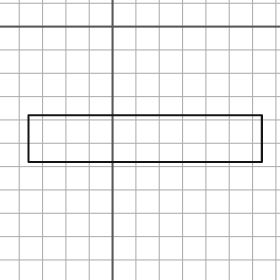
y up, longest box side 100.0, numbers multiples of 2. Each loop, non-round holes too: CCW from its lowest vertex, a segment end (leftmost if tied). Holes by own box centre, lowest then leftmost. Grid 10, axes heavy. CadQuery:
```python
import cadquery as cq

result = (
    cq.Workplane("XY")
    .moveTo(-36.0, -58.0)
    .lineTo(64.0, -58.0)
    .lineTo(64.0, -38.0)
    .lineTo(-36.0, -38.0)
    .close()
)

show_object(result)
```